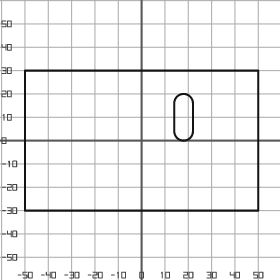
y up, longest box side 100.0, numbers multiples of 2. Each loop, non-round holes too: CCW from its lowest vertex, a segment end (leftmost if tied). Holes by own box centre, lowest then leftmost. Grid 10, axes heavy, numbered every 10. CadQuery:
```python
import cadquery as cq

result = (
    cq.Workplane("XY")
    .moveTo(-50.0, -30.0)
    .lineTo(50.0, -30.0)
    .lineTo(50.0, 30.0)
    .lineTo(-50.0, 30.0)
    .close()
    .moveTo(14.0, 4.0)
    .threePointArc((18.0, 0.0), (22.0, 4.0))
    .lineTo(22.0, 16.0)
    .threePointArc((18.0, 20.0), (14.0, 16.0))
    .close()
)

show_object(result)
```